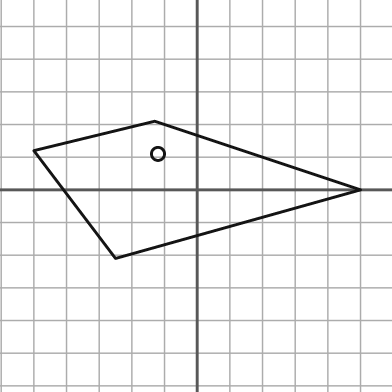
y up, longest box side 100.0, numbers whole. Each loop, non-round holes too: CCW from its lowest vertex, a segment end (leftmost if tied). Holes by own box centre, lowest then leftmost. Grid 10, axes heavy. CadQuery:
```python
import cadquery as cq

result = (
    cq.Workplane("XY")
    .moveTo(-25.0, -21.0)
    .lineTo(50.0, 0.0)
    .lineTo(-13.0, 21.0)
    .lineTo(-50.0, 12.0)
    .close()
    .moveTo(-12.0, 11.0)
    .circle(2.0)
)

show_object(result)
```